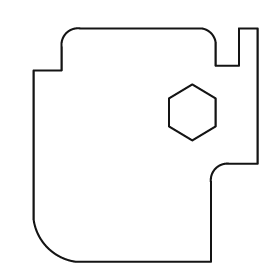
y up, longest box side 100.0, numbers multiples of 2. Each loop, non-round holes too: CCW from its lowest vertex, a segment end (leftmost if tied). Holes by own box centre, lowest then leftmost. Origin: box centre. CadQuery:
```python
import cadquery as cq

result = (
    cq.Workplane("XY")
    .moveTo(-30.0, -50.0)
    .lineTo(28.0, -50.0)
    .lineTo(28.0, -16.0)
    .threePointArc((30.0, -10.0), (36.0, -8.0))
    .lineTo(48.0, -8.0)
    .lineTo(48.0, 50.0)
    .lineTo(40.0, 50.0)
    .lineTo(40.0, 34.0)
    .lineTo(30.0, 34.0)
    .lineTo(30.0, 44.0)
    .threePointArc((28.0, 48.0), (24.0, 50.0))
    .lineTo(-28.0, 50.0)
    .threePointArc((-34.0, 48.0), (-36.0, 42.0))
    .lineTo(-36.0, 32.0)
    .lineTo(-48.0, 32.0)
    .lineTo(-48.0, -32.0)
    .threePointArc((-42.0, -44.0), (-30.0, -50.0))
    .close()
    .moveTo(20.0, 2.0)
    .lineTo(30.0, 8.0)
    .lineTo(30.0, 20.0)
    .lineTo(20.0, 26.0)
    .lineTo(10.0, 20.0)
    .lineTo(10.0, 8.0)
    .close()
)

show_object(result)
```